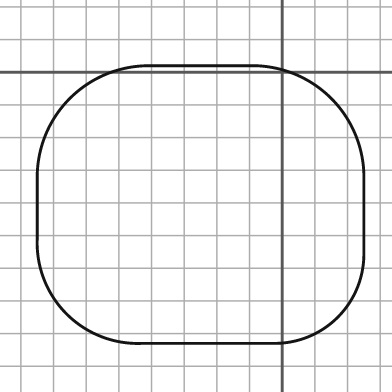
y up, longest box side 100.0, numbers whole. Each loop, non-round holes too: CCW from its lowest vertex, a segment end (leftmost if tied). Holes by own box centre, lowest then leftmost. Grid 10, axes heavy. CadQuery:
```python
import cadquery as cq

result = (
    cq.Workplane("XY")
    .moveTo(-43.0, -83.0)
    .lineTo(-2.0, -83.0)
    .threePointArc((17.0, -75.0), (25.0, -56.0))
    .lineTo(25.0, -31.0)
    .threePointArc((15.0, -8.0), (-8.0, 2.0))
    .lineTo(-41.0, 2.0)
    .threePointArc((-65.0, -8.0), (-75.0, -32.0))
    .lineTo(-75.0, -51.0)
    .threePointArc((-66.0, -74.0), (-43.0, -83.0))
    .close()
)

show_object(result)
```